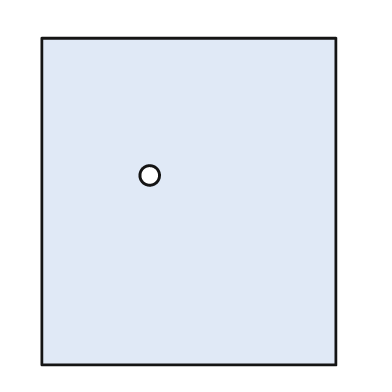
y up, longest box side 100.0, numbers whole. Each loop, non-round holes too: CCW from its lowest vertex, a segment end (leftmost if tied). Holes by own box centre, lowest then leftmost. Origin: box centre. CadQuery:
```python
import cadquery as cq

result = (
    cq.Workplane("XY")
    .moveTo(-45.0, -50.0)
    .lineTo(45.0, -50.0)
    .lineTo(45.0, 50.0)
    .lineTo(-45.0, 50.0)
    .close()
    .moveTo(-12.0, 8.0)
    .circle(3.0)
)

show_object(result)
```